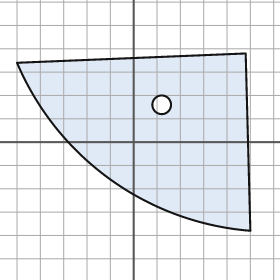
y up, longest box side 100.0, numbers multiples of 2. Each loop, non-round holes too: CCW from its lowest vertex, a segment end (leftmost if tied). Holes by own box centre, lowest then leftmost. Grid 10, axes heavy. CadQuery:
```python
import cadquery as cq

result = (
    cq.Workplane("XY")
    .moveTo(50.0, -38.0)
    .lineTo(48.0, 38.0)
    .lineTo(-50.0, 34.0)
    .threePointArc((-10.0, -16.0), (50.0, -38.0))
    .close()
    .moveTo(12.0, 16.0)
    .circle(4.0)
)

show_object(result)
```